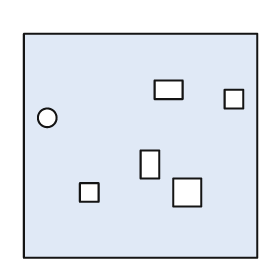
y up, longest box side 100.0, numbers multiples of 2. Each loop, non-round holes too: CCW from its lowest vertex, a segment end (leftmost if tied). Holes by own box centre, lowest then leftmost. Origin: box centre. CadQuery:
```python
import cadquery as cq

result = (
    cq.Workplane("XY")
    .moveTo(-50.0, -48.0)
    .lineTo(50.0, -48.0)
    .lineTo(50.0, 48.0)
    .lineTo(-50.0, 48.0)
    .close()
    .moveTo(-26.0, -24.0)
    .lineTo(-18.0, -24.0)
    .lineTo(-18.0, -16.0)
    .lineTo(-26.0, -16.0)
    .close()
    .moveTo(14.0, -26.0)
    .lineTo(26.0, -26.0)
    .lineTo(26.0, -14.0)
    .lineTo(14.0, -14.0)
    .close()
    .moveTo(0.0, -14.0)
    .lineTo(8.0, -14.0)
    .lineTo(8.0, -2.0)
    .lineTo(0.0, -2.0)
    .close()
    .moveTo(-40.0, 12.0)
    .circle(4.0)
    .moveTo(36.0, 16.0)
    .lineTo(44.0, 16.0)
    .lineTo(44.0, 24.0)
    .lineTo(36.0, 24.0)
    .close()
    .moveTo(6.0, 20.0)
    .lineTo(18.0, 20.0)
    .lineTo(18.0, 28.0)
    .lineTo(6.0, 28.0)
    .close()
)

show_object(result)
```